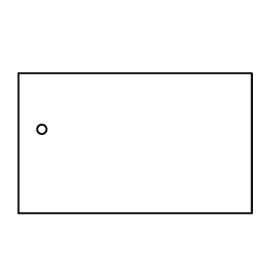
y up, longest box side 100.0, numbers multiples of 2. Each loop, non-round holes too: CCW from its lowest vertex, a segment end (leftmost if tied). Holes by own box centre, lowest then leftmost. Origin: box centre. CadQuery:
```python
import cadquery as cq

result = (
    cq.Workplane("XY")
    .moveTo(-50.0, -30.0)
    .lineTo(50.0, -30.0)
    .lineTo(50.0, 30.0)
    .lineTo(-50.0, 30.0)
    .close()
    .moveTo(-40.0, 6.0)
    .circle(2.0)
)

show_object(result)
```